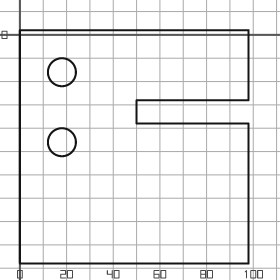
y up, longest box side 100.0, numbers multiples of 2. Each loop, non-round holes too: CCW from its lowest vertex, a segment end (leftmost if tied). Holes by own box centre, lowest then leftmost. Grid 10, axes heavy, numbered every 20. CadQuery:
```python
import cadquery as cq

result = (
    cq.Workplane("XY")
    .moveTo(0.0, -98.0)
    .lineTo(98.0, -98.0)
    .lineTo(98.0, -38.0)
    .lineTo(50.0, -38.0)
    .lineTo(50.0, -28.0)
    .lineTo(98.0, -28.0)
    .lineTo(98.0, 2.0)
    .lineTo(0.0, 2.0)
    .close()
    .moveTo(18.0, -46.0)
    .circle(6.0)
    .moveTo(18.0, -16.0)
    .circle(6.0)
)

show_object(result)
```